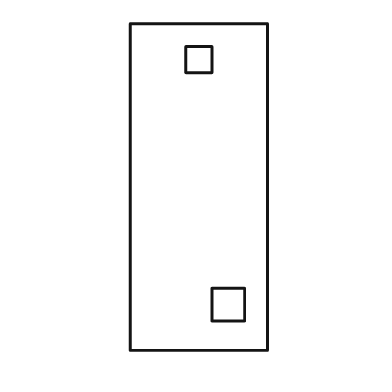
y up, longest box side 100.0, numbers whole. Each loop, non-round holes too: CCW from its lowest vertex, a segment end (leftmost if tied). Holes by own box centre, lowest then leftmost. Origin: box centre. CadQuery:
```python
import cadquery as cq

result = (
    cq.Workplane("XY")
    .moveTo(-21.0, -50.0)
    .lineTo(21.0, -50.0)
    .lineTo(21.0, 50.0)
    .lineTo(-21.0, 50.0)
    .close()
    .moveTo(4.0, -41.0)
    .lineTo(14.0, -41.0)
    .lineTo(14.0, -31.0)
    .lineTo(4.0, -31.0)
    .close()
    .moveTo(-4.0, 35.0)
    .lineTo(4.0, 35.0)
    .lineTo(4.0, 43.0)
    .lineTo(-4.0, 43.0)
    .close()
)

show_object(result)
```